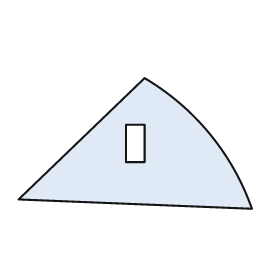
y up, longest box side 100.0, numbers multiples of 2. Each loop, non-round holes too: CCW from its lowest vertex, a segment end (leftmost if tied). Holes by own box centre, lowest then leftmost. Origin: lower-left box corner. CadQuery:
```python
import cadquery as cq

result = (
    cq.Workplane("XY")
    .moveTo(100.0, 0.0)
    .threePointArc((82.0, 32.0), (54.0, 56.0))
    .lineTo(0.0, 4.0)
    .close()
    .moveTo(46.0, 20.0)
    .lineTo(54.0, 20.0)
    .lineTo(54.0, 36.0)
    .lineTo(46.0, 36.0)
    .close()
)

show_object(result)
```